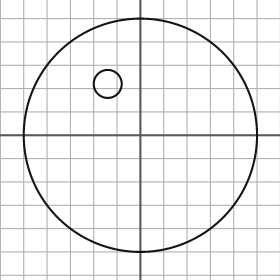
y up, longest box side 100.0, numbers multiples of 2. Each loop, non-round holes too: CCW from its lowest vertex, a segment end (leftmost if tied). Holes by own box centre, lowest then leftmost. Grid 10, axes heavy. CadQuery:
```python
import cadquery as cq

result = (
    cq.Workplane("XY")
    .moveTo(0.0, 0.0)
    .circle(50.0)
    .moveTo(-14.0, 22.0)
    .circle(6.0)
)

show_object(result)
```